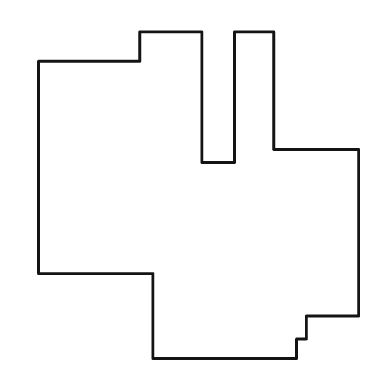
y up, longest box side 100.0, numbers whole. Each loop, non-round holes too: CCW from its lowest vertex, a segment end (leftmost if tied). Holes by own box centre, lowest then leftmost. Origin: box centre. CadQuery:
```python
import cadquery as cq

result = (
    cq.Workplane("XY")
    .moveTo(-14.0, -50.0)
    .lineTo(30.0, -50.0)
    .lineTo(30.0, -44.0)
    .lineTo(33.0, -44.0)
    .lineTo(33.0, -37.0)
    .lineTo(49.0, -37.0)
    .lineTo(49.0, 14.0)
    .lineTo(23.0, 14.0)
    .lineTo(23.0, 50.0)
    .lineTo(11.0, 50.0)
    .lineTo(11.0, 10.0)
    .lineTo(1.0, 10.0)
    .lineTo(1.0, 50.0)
    .lineTo(-18.0, 50.0)
    .lineTo(-18.0, 41.0)
    .lineTo(-49.0, 41.0)
    .lineTo(-49.0, -24.0)
    .lineTo(-14.0, -24.0)
    .close()
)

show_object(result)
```